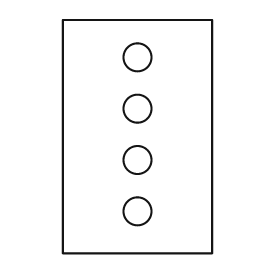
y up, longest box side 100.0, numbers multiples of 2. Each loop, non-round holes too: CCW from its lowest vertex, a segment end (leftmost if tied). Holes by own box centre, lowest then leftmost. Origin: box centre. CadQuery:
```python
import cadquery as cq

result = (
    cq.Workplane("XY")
    .moveTo(-32.0, -50.0)
    .lineTo(32.0, -50.0)
    .lineTo(32.0, 50.0)
    .lineTo(-32.0, 50.0)
    .close()
    .moveTo(0.0, -32.0)
    .circle(6.0)
    .moveTo(0.0, -10.0)
    .circle(6.0)
    .moveTo(0.0, 12.0)
    .circle(6.0)
    .moveTo(0.0, 34.0)
    .circle(6.0)
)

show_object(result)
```